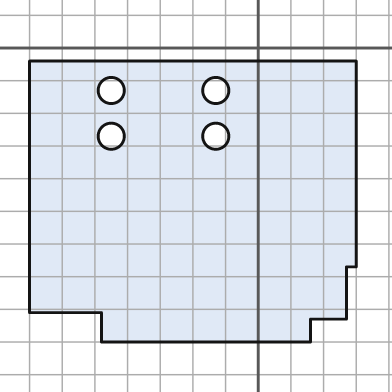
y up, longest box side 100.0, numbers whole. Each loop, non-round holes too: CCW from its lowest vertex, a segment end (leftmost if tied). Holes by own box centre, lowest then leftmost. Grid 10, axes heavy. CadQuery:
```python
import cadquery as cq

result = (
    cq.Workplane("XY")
    .moveTo(-48.0, -90.0)
    .lineTo(16.0, -90.0)
    .lineTo(16.0, -83.0)
    .lineTo(27.0, -83.0)
    .lineTo(27.0, -67.0)
    .lineTo(30.0, -67.0)
    .lineTo(30.0, -4.0)
    .lineTo(-70.0, -4.0)
    .lineTo(-70.0, -81.0)
    .lineTo(-48.0, -81.0)
    .close()
    .moveTo(-45.0, -27.0)
    .circle(4.0)
    .moveTo(-13.0, -27.0)
    .circle(4.0)
    .moveTo(-45.0, -13.0)
    .circle(4.0)
    .moveTo(-13.0, -13.0)
    .circle(4.0)
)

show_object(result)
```